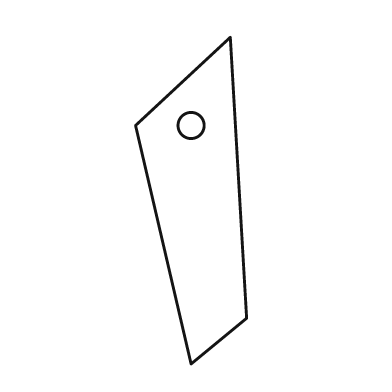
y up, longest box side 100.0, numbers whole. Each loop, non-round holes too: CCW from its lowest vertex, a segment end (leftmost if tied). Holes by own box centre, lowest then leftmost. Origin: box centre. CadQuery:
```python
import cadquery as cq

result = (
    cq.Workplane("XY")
    .moveTo(0.0, -50.0)
    .lineTo(17.0, -36.0)
    .lineTo(12.0, 50.0)
    .lineTo(-17.0, 23.0)
    .close()
    .moveTo(0.0, 23.0)
    .circle(4.0)
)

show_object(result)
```